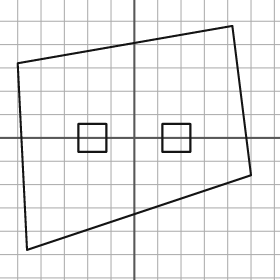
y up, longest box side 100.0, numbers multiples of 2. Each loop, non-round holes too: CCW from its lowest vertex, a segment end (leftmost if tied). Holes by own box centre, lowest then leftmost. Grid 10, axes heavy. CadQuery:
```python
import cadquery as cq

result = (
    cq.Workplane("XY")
    .moveTo(-46.0, -48.0)
    .lineTo(50.0, -16.0)
    .lineTo(42.0, 48.0)
    .lineTo(-50.0, 32.0)
    .close()
    .moveTo(-24.0, -6.0)
    .lineTo(-12.0, -6.0)
    .lineTo(-12.0, 6.0)
    .lineTo(-24.0, 6.0)
    .close()
    .moveTo(12.0, -6.0)
    .lineTo(24.0, -6.0)
    .lineTo(24.0, 6.0)
    .lineTo(12.0, 6.0)
    .close()
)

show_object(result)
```